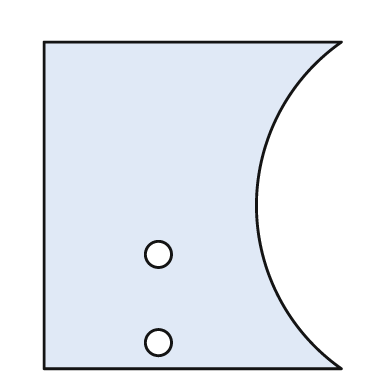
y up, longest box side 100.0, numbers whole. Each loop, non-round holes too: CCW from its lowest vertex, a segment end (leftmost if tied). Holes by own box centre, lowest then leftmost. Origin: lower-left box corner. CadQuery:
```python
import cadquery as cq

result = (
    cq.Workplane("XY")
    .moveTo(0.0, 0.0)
    .lineTo(91.0, 0.0)
    .threePointArc((65.0, 50.0), (91.0, 100.0))
    .lineTo(0.0, 100.0)
    .close()
    .moveTo(35.0, 8.0)
    .circle(4.0)
    .moveTo(35.0, 35.0)
    .circle(4.0)
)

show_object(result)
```